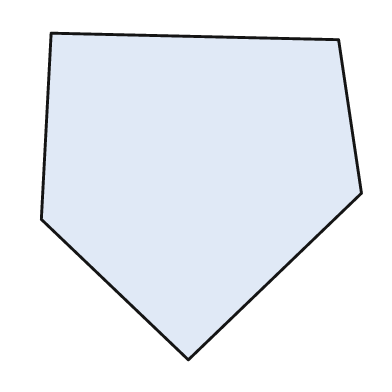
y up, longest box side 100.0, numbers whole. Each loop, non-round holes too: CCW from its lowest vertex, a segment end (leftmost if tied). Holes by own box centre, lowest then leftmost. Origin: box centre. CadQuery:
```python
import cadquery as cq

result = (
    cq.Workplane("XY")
    .moveTo(-4.0, -50.0)
    .lineTo(49.0, 1.0)
    .lineTo(42.0, 48.0)
    .lineTo(-46.0, 50.0)
    .lineTo(-49.0, -7.0)
    .close()
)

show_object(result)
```